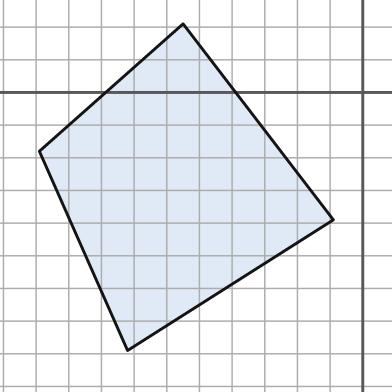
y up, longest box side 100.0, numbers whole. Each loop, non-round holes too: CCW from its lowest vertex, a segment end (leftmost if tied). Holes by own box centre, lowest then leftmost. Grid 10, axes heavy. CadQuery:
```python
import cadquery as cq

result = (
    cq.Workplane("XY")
    .moveTo(-72.0, -79.0)
    .lineTo(-9.0, -39.0)
    .lineTo(-55.0, 21.0)
    .lineTo(-99.0, -18.0)
    .close()
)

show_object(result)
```